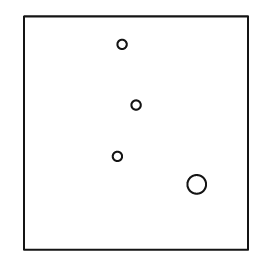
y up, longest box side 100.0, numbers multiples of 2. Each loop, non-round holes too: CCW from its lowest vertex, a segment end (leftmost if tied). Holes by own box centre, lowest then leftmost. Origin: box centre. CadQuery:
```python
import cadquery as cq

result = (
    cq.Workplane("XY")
    .moveTo(-48.0, -50.0)
    .lineTo(48.0, -50.0)
    .lineTo(48.0, 50.0)
    .lineTo(-48.0, 50.0)
    .close()
    .moveTo(26.0, -22.0)
    .circle(4.0)
    .moveTo(-8.0, -10.0)
    .circle(2.0)
    .moveTo(0.0, 12.0)
    .circle(2.0)
    .moveTo(-6.0, 38.0)
    .circle(2.0)
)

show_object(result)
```